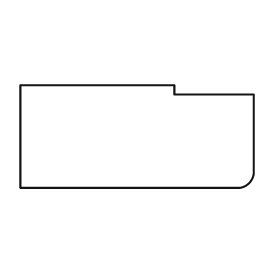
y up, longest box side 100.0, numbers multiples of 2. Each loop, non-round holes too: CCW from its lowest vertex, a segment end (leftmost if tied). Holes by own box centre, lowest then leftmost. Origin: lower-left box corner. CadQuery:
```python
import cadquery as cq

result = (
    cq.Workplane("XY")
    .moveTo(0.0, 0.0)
    .lineTo(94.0, 0.0)
    .threePointArc((98.0, 2.0), (100.0, 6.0))
    .lineTo(100.0, 40.0)
    .lineTo(66.0, 40.0)
    .lineTo(66.0, 44.0)
    .lineTo(0.0, 44.0)
    .close()
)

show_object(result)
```